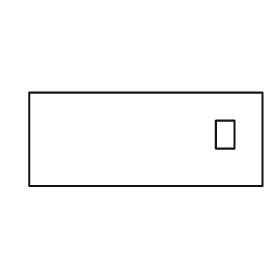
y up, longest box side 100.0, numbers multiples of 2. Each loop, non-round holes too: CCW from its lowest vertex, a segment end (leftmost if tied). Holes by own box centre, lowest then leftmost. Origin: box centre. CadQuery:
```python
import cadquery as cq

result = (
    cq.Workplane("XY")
    .moveTo(-50.0, -20.0)
    .lineTo(50.0, -20.0)
    .lineTo(50.0, 20.0)
    .lineTo(-50.0, 20.0)
    .close()
    .moveTo(30.0, -4.0)
    .lineTo(38.0, -4.0)
    .lineTo(38.0, 8.0)
    .lineTo(30.0, 8.0)
    .close()
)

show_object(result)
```